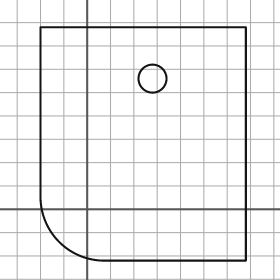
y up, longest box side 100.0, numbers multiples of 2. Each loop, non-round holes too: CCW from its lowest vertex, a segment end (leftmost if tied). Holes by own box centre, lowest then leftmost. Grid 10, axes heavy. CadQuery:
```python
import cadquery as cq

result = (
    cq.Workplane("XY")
    .moveTo(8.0, -22.0)
    .lineTo(68.0, -22.0)
    .lineTo(68.0, 78.0)
    .lineTo(-20.0, 78.0)
    .lineTo(-20.0, 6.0)
    .threePointArc((-12.0, -14.0), (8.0, -22.0))
    .close()
    .moveTo(28.0, 56.0)
    .circle(6.0)
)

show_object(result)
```